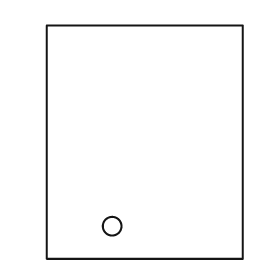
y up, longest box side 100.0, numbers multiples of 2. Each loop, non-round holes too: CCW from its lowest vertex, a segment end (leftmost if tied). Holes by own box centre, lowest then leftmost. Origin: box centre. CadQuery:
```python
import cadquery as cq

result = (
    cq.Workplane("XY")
    .moveTo(-42.0, -50.0)
    .lineTo(42.0, -50.0)
    .lineTo(42.0, 50.0)
    .lineTo(-42.0, 50.0)
    .close()
    .moveTo(-14.0, -36.0)
    .circle(4.0)
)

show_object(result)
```